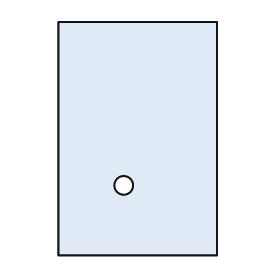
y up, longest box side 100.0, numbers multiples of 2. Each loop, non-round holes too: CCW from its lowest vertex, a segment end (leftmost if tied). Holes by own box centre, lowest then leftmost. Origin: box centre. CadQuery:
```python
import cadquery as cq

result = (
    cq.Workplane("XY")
    .moveTo(-34.0, -50.0)
    .lineTo(34.0, -50.0)
    .lineTo(34.0, 50.0)
    .lineTo(-34.0, 50.0)
    .close()
    .moveTo(-6.0, -20.0)
    .circle(4.0)
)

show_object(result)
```